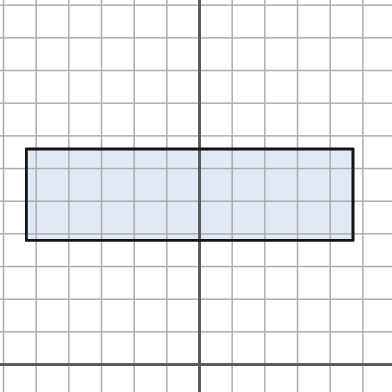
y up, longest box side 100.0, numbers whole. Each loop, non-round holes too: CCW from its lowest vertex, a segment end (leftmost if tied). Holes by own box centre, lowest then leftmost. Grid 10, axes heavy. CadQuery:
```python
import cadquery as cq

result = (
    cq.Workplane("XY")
    .moveTo(-53.0, 38.0)
    .lineTo(47.0, 38.0)
    .lineTo(47.0, 66.0)
    .lineTo(-53.0, 66.0)
    .close()
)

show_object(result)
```